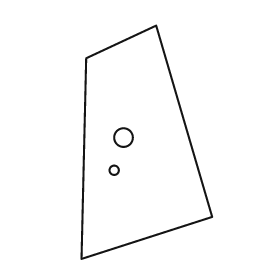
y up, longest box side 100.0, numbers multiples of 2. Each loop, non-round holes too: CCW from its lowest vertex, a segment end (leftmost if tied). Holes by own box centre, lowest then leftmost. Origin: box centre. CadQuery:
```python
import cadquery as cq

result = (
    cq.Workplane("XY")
    .moveTo(-28.0, -50.0)
    .lineTo(28.0, -32.0)
    .lineTo(4.0, 50.0)
    .lineTo(-26.0, 36.0)
    .close()
    .moveTo(-14.0, -12.0)
    .circle(2.0)
    .moveTo(-10.0, 2.0)
    .circle(4.0)
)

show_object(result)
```